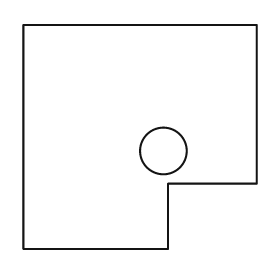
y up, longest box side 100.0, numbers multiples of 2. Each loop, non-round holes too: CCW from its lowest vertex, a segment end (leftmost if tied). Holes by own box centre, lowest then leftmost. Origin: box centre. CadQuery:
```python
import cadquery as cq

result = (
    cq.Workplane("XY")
    .moveTo(-50.0, -48.0)
    .lineTo(12.0, -48.0)
    .lineTo(12.0, -20.0)
    .lineTo(50.0, -20.0)
    .lineTo(50.0, 48.0)
    .lineTo(-50.0, 48.0)
    .close()
    .moveTo(10.0, -6.0)
    .circle(10.0)
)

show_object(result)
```